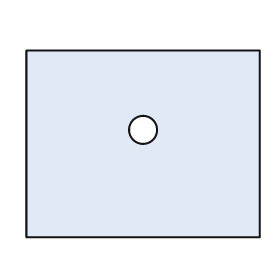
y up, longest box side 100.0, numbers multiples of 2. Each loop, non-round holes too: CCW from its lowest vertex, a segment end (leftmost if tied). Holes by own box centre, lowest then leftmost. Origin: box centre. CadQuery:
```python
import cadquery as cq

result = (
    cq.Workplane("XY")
    .moveTo(-50.0, -40.0)
    .lineTo(50.0, -40.0)
    .lineTo(50.0, 40.0)
    .lineTo(-50.0, 40.0)
    .close()
    .moveTo(0.0, 6.0)
    .circle(6.0)
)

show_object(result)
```